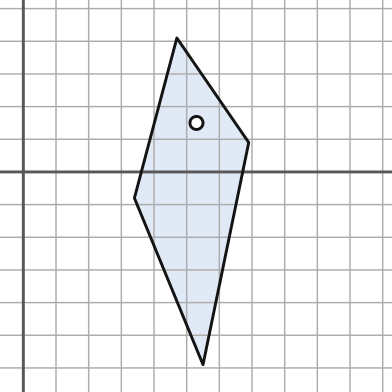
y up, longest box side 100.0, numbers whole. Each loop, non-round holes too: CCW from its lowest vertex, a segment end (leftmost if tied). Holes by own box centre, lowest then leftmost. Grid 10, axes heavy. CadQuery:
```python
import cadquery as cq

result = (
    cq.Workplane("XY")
    .moveTo(55.0, -59.0)
    .lineTo(69.0, 9.0)
    .lineTo(47.0, 41.0)
    .lineTo(34.0, -8.0)
    .close()
    .moveTo(53.0, 15.0)
    .circle(2.0)
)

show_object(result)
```